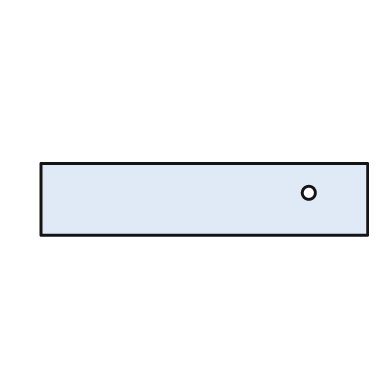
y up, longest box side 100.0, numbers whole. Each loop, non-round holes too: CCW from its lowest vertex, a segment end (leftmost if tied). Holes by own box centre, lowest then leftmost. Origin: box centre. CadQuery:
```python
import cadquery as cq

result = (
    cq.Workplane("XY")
    .moveTo(-50.0, -11.0)
    .lineTo(50.0, -11.0)
    .lineTo(50.0, 11.0)
    .lineTo(-50.0, 11.0)
    .close()
    .moveTo(32.0, 2.0)
    .circle(2.0)
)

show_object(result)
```